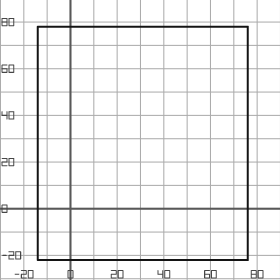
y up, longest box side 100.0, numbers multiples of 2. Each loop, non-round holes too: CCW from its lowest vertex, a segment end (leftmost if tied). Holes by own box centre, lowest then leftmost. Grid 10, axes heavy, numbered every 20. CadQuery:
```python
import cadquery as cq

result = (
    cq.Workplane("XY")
    .moveTo(-14.0, -22.0)
    .lineTo(76.0, -22.0)
    .lineTo(76.0, 78.0)
    .lineTo(-14.0, 78.0)
    .close()
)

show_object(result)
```